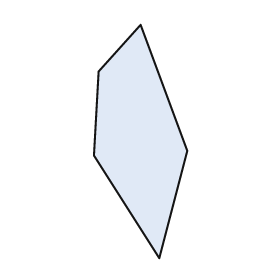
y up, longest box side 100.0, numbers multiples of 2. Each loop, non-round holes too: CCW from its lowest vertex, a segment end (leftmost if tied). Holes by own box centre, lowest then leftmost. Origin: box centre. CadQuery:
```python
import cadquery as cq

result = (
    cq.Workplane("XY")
    .moveTo(8.0, -50.0)
    .lineTo(20.0, -4.0)
    .lineTo(0.0, 50.0)
    .lineTo(-18.0, 30.0)
    .lineTo(-20.0, -6.0)
    .close()
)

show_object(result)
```